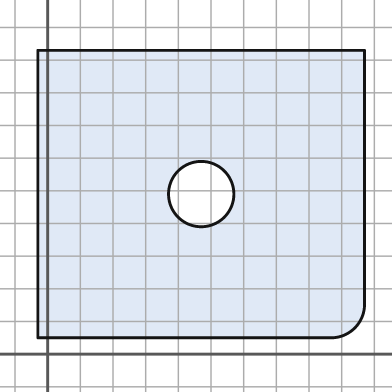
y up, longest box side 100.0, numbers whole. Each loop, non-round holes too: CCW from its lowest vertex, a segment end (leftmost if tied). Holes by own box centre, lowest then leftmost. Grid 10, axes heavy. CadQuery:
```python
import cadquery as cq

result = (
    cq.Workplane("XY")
    .moveTo(-3.0, 5.0)
    .lineTo(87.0, 5.0)
    .threePointArc((94.0, 8.0), (97.0, 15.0))
    .lineTo(97.0, 93.0)
    .lineTo(-3.0, 93.0)
    .close()
    .moveTo(47.0, 49.0)
    .circle(10.0)
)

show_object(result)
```